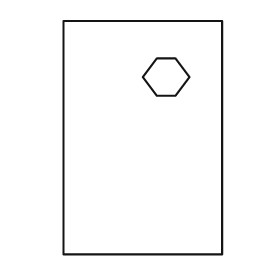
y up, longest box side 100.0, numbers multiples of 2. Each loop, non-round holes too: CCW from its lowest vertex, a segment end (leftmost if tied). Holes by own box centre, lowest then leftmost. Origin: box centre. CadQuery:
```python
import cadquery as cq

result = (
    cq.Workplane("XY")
    .moveTo(-34.0, -50.0)
    .lineTo(34.0, -50.0)
    .lineTo(34.0, 50.0)
    .lineTo(-34.0, 50.0)
    .close()
    .moveTo(6.0, 18.0)
    .lineTo(14.0, 18.0)
    .lineTo(20.0, 26.0)
    .lineTo(14.0, 34.0)
    .lineTo(6.0, 34.0)
    .lineTo(0.0, 26.0)
    .close()
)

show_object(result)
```